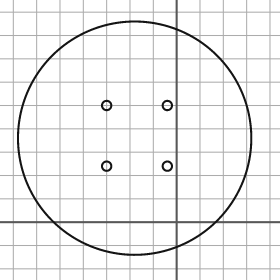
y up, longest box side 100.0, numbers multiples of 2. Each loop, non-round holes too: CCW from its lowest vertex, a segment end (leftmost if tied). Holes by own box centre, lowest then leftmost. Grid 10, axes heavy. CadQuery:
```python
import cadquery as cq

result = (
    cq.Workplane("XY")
    .moveTo(-18.0, 36.0)
    .circle(50.0)
    .moveTo(-30.0, 24.0)
    .circle(2.0)
    .moveTo(-4.0, 24.0)
    .circle(2.0)
    .moveTo(-30.0, 50.0)
    .circle(2.0)
    .moveTo(-4.0, 50.0)
    .circle(2.0)
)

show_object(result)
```